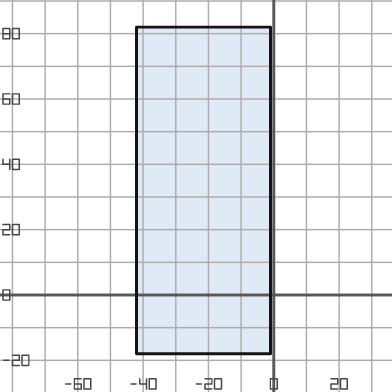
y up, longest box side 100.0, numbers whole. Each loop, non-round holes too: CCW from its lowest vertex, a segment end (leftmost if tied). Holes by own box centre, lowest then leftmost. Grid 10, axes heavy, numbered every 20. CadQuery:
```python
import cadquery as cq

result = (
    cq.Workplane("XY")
    .moveTo(-42.0, -18.0)
    .lineTo(-1.0, -18.0)
    .lineTo(-1.0, 82.0)
    .lineTo(-42.0, 82.0)
    .close()
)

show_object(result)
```